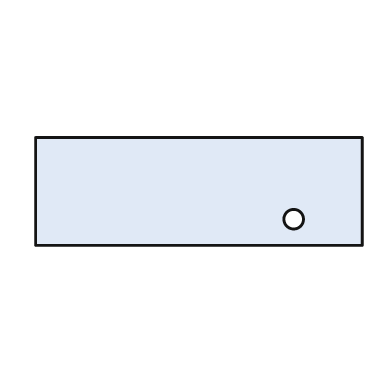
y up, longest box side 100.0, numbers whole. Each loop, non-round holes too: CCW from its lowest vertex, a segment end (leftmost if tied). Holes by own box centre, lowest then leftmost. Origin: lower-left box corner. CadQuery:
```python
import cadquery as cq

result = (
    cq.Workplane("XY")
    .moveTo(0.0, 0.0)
    .lineTo(100.0, 0.0)
    .lineTo(100.0, 33.0)
    .lineTo(0.0, 33.0)
    .close()
    .moveTo(79.0, 8.0)
    .circle(3.0)
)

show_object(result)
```